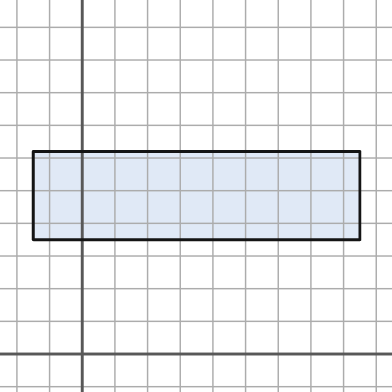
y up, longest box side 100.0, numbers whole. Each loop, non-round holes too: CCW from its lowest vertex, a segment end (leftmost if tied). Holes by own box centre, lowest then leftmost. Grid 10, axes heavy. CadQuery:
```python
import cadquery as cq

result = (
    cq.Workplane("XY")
    .moveTo(-15.0, 35.0)
    .lineTo(85.0, 35.0)
    .lineTo(85.0, 62.0)
    .lineTo(-15.0, 62.0)
    .close()
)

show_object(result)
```